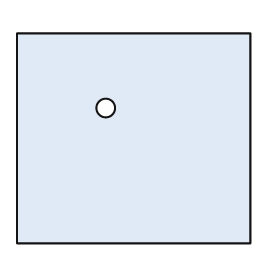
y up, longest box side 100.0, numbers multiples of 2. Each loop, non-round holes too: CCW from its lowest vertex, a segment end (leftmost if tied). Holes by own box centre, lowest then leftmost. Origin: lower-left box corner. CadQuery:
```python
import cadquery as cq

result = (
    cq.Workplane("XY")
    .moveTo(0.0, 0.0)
    .lineTo(100.0, 0.0)
    .lineTo(100.0, 90.0)
    .lineTo(0.0, 90.0)
    .close()
    .moveTo(38.0, 58.0)
    .circle(4.0)
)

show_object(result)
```